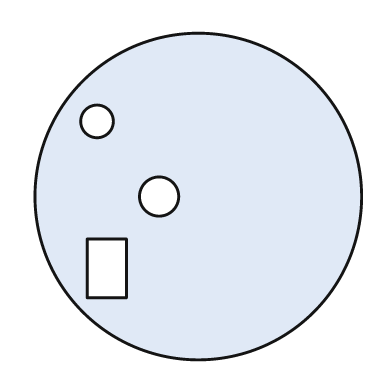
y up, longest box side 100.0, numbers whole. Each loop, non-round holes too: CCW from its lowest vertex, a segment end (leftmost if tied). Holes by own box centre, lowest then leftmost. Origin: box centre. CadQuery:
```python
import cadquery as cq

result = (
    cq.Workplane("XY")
    .moveTo(0.0, 0.0)
    .circle(50.0)
    .moveTo(-34.0, -31.0)
    .lineTo(-22.0, -31.0)
    .lineTo(-22.0, -13.0)
    .lineTo(-34.0, -13.0)
    .close()
    .moveTo(-12.0, 0.0)
    .circle(6.0)
    .moveTo(-31.0, 23.0)
    .circle(5.0)
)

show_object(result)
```